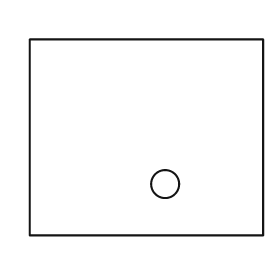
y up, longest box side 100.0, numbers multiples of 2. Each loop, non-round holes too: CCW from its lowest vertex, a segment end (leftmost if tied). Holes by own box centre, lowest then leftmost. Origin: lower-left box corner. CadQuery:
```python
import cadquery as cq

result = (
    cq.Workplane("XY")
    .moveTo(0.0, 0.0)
    .lineTo(100.0, 0.0)
    .lineTo(100.0, 84.0)
    .lineTo(0.0, 84.0)
    .close()
    .moveTo(58.0, 22.0)
    .circle(6.0)
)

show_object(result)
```